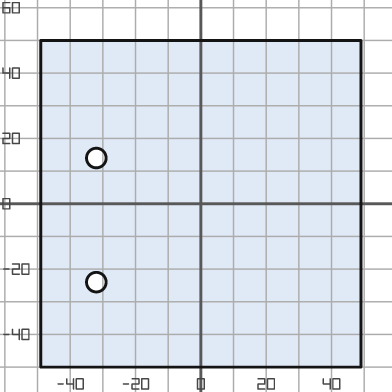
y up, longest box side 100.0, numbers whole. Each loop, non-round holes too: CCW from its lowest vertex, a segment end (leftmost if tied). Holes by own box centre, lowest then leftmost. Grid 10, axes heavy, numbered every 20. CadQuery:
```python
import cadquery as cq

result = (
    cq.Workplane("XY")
    .moveTo(-49.0, -50.0)
    .lineTo(49.0, -50.0)
    .lineTo(49.0, 50.0)
    .lineTo(-49.0, 50.0)
    .close()
    .moveTo(-32.0, -24.0)
    .circle(3.0)
    .moveTo(-32.0, 14.0)
    .circle(3.0)
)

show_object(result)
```